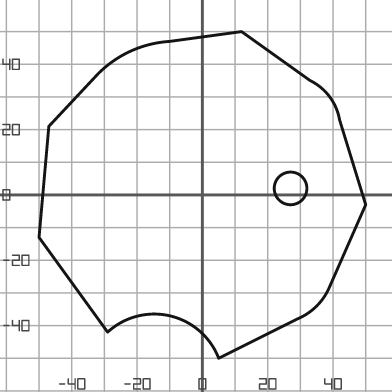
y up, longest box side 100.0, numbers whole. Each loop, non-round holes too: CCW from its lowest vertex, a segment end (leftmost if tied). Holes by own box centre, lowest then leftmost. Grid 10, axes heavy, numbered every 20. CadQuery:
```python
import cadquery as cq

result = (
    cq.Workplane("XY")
    .moveTo(5.0, -50.0)
    .lineTo(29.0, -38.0)
    .threePointArc((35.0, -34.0), (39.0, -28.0))
    .lineTo(50.0, -3.0)
    .lineTo(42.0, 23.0)
    .threePointArc((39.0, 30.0), (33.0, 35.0))
    .lineTo(12.0, 50.0)
    .lineTo(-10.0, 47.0)
    .threePointArc((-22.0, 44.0), (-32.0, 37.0))
    .lineTo(-47.0, 21.0)
    .lineTo(-50.0, -13.0)
    .lineTo(-29.0, -42.0)
    .threePointArc((-10.0, -37.0), (5.0, -50.0))
    .close()
    .moveTo(27.0, 2.0)
    .circle(5.0)
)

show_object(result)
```